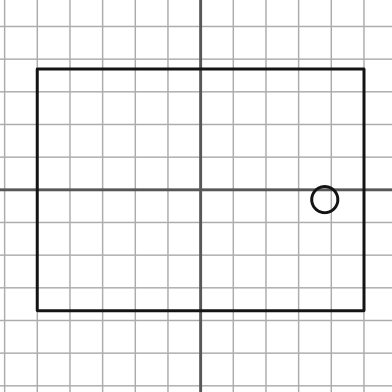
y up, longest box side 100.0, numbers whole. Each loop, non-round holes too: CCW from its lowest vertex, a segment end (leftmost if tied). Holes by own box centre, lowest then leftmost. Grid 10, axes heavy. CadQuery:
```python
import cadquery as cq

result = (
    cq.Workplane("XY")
    .moveTo(-50.0, -37.0)
    .lineTo(50.0, -37.0)
    .lineTo(50.0, 37.0)
    .lineTo(-50.0, 37.0)
    .close()
    .moveTo(38.0, -3.0)
    .circle(4.0)
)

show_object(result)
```